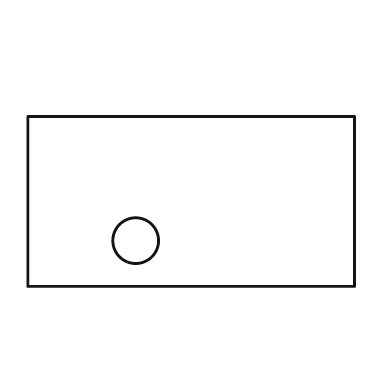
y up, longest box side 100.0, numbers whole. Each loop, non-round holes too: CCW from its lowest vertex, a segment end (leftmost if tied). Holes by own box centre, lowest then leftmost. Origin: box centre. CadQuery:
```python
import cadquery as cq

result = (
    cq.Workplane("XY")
    .moveTo(-50.0, -26.0)
    .lineTo(50.0, -26.0)
    .lineTo(50.0, 26.0)
    .lineTo(-50.0, 26.0)
    .close()
    .moveTo(-17.0, -12.0)
    .circle(7.0)
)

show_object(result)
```